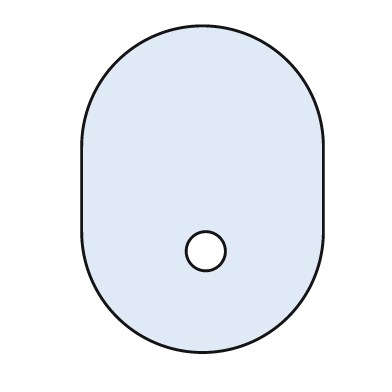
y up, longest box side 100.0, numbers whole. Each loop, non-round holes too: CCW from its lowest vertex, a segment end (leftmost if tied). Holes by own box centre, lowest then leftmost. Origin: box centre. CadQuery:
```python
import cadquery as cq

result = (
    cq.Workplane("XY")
    .moveTo(-37.0, -13.0)
    .threePointArc((0.0, -50.0), (37.0, -13.0))
    .lineTo(37.0, 13.0)
    .threePointArc((0.0, 50.0), (-37.0, 13.0))
    .close()
    .moveTo(1.0, -19.0)
    .circle(6.0)
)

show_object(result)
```